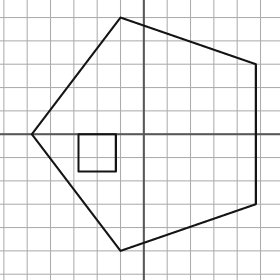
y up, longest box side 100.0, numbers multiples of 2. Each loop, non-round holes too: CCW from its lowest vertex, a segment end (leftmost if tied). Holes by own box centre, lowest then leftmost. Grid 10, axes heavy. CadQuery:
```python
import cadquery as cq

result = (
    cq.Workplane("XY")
    .moveTo(-10.0, -50.0)
    .lineTo(48.0, -30.0)
    .lineTo(48.0, 30.0)
    .lineTo(-10.0, 50.0)
    .lineTo(-48.0, 0.0)
    .close()
    .moveTo(-28.0, -16.0)
    .lineTo(-12.0, -16.0)
    .lineTo(-12.0, 0.0)
    .lineTo(-28.0, 0.0)
    .close()
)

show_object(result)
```